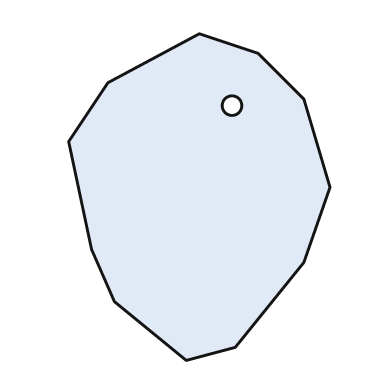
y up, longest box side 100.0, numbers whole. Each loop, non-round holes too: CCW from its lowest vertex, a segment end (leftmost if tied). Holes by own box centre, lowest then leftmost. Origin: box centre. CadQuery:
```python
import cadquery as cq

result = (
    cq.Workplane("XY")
    .moveTo(-4.0, -50.0)
    .lineTo(11.0, -46.0)
    .lineTo(32.0, -20.0)
    .lineTo(40.0, 3.0)
    .lineTo(32.0, 30.0)
    .lineTo(18.0, 44.0)
    .lineTo(0.0, 50.0)
    .lineTo(-28.0, 35.0)
    .lineTo(-40.0, 17.0)
    .lineTo(-33.0, -16.0)
    .lineTo(-26.0, -32.0)
    .close()
    .moveTo(10.0, 28.0)
    .circle(3.0)
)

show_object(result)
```